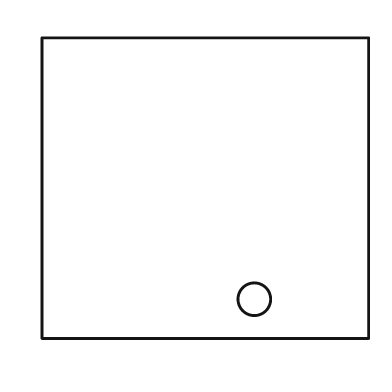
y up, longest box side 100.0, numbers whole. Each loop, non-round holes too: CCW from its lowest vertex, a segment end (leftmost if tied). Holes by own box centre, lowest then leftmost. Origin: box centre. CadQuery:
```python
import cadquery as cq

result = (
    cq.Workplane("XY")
    .moveTo(-50.0, -46.0)
    .lineTo(50.0, -46.0)
    .lineTo(50.0, 46.0)
    .lineTo(-50.0, 46.0)
    .close()
    .moveTo(15.0, -34.0)
    .circle(5.0)
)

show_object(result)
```